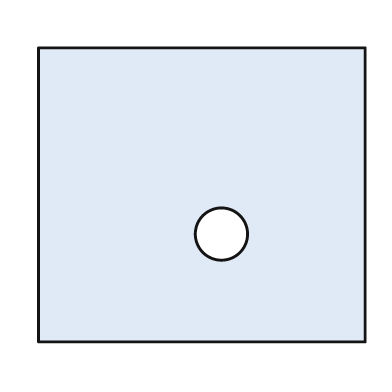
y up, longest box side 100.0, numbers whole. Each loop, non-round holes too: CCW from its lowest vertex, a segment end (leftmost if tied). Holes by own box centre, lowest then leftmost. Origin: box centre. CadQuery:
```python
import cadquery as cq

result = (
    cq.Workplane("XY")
    .moveTo(-50.0, -45.0)
    .lineTo(50.0, -45.0)
    .lineTo(50.0, 45.0)
    .lineTo(-50.0, 45.0)
    .close()
    .moveTo(6.0, -12.0)
    .circle(8.0)
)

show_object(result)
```